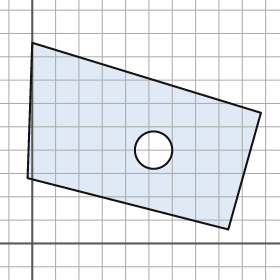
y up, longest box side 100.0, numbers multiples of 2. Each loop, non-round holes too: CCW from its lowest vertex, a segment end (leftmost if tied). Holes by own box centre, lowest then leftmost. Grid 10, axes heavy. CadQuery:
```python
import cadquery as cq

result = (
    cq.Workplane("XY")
    .moveTo(84.0, 6.0)
    .lineTo(98.0, 56.0)
    .lineTo(0.0, 86.0)
    .lineTo(-2.0, 28.0)
    .close()
    .moveTo(52.0, 40.0)
    .circle(8.0)
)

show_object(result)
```